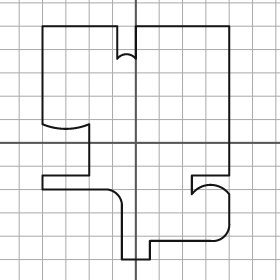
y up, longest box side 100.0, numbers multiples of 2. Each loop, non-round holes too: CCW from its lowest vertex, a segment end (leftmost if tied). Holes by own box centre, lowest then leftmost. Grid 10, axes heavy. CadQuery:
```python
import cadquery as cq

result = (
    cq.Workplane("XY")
    .moveTo(-6.0, -50.0)
    .lineTo(6.0, -50.0)
    .lineTo(6.0, -42.0)
    .lineTo(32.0, -42.0)
    .threePointArc((38.0, -40.0), (40.0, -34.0))
    .lineTo(40.0, -22.0)
    .threePointArc((32.0, -18.0), (24.0, -22.0))
    .lineTo(24.0, -14.0)
    .lineTo(40.0, -14.0)
    .lineTo(40.0, 50.0)
    .lineTo(0.0, 50.0)
    .lineTo(0.0, 36.0)
    .threePointArc((-4.0, 38.0), (-8.0, 36.0))
    .lineTo(-8.0, 50.0)
    .lineTo(-40.0, 50.0)
    .lineTo(-40.0, 8.0)
    .threePointArc((-30.0, 6.0), (-20.0, 8.0))
    .lineTo(-20.0, -14.0)
    .lineTo(-40.0, -14.0)
    .lineTo(-40.0, -20.0)
    .lineTo(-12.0, -20.0)
    .threePointArc((-8.0, -22.0), (-6.0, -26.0))
    .close()
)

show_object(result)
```